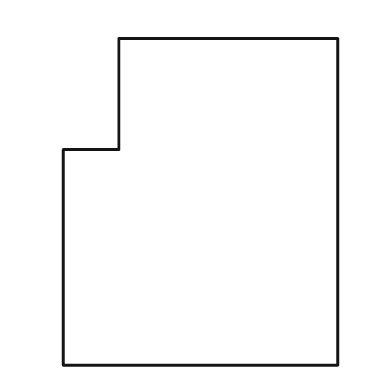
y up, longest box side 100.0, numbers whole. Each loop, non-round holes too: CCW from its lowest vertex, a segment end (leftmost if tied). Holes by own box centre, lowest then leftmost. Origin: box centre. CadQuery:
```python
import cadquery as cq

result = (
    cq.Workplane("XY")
    .moveTo(-42.0, -50.0)
    .lineTo(42.0, -50.0)
    .lineTo(42.0, 50.0)
    .lineTo(-25.0, 50.0)
    .lineTo(-25.0, 16.0)
    .lineTo(-42.0, 16.0)
    .close()
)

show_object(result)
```